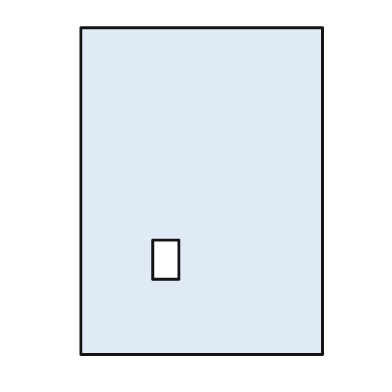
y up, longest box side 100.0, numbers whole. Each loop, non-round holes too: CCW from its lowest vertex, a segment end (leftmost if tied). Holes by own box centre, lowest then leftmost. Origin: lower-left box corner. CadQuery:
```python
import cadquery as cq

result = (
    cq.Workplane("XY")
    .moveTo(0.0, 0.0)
    .lineTo(74.0, 0.0)
    .lineTo(74.0, 100.0)
    .lineTo(0.0, 100.0)
    .close()
    .moveTo(22.0, 23.0)
    .lineTo(30.0, 23.0)
    .lineTo(30.0, 35.0)
    .lineTo(22.0, 35.0)
    .close()
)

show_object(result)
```